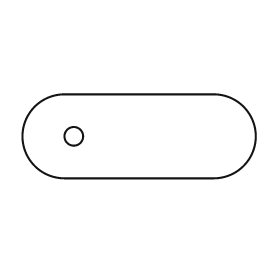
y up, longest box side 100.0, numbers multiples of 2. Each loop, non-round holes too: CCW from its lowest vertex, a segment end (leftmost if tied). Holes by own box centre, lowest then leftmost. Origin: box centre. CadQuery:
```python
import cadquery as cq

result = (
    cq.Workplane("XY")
    .moveTo(-32.0, -18.0)
    .lineTo(32.0, -18.0)
    .threePointArc((50.0, 0.0), (32.0, 18.0))
    .lineTo(-32.0, 18.0)
    .threePointArc((-50.0, 0.0), (-32.0, -18.0))
    .close()
    .moveTo(-28.0, 0.0)
    .circle(4.0)
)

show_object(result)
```